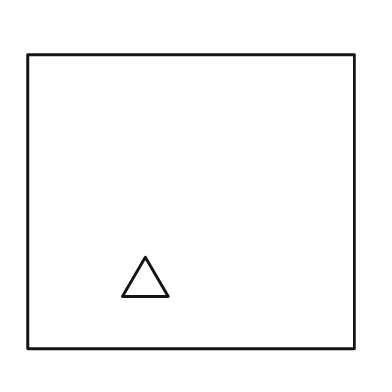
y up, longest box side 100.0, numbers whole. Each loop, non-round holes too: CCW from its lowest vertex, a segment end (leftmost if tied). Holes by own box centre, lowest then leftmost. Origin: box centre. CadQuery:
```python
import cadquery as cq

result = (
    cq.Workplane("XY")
    .moveTo(-50.0, -45.0)
    .lineTo(50.0, -45.0)
    .lineTo(50.0, 45.0)
    .lineTo(-50.0, 45.0)
    .close()
    .moveTo(-21.0, -29.0)
    .lineTo(-7.0, -29.0)
    .lineTo(-14.0, -17.0)
    .close()
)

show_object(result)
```